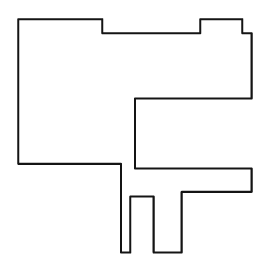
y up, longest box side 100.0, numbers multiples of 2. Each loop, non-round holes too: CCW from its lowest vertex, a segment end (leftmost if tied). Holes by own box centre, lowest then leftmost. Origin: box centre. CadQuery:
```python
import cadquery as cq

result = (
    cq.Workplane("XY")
    .moveTo(-6.0, -50.0)
    .lineTo(-2.0, -50.0)
    .lineTo(-2.0, -26.0)
    .lineTo(8.0, -26.0)
    .lineTo(8.0, -50.0)
    .lineTo(20.0, -50.0)
    .lineTo(20.0, -24.0)
    .lineTo(50.0, -24.0)
    .lineTo(50.0, -14.0)
    .lineTo(0.0, -14.0)
    .lineTo(0.0, 16.0)
    .lineTo(50.0, 16.0)
    .lineTo(50.0, 44.0)
    .lineTo(46.0, 44.0)
    .lineTo(46.0, 50.0)
    .lineTo(28.0, 50.0)
    .lineTo(28.0, 44.0)
    .lineTo(-14.0, 44.0)
    .lineTo(-14.0, 50.0)
    .lineTo(-50.0, 50.0)
    .lineTo(-50.0, -12.0)
    .lineTo(-6.0, -12.0)
    .close()
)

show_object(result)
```